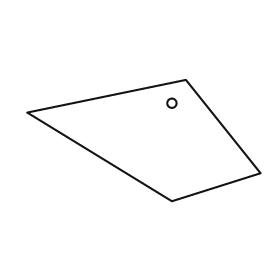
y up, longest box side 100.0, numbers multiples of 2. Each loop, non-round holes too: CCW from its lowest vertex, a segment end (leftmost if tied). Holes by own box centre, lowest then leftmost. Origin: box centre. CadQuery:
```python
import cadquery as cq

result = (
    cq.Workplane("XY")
    .moveTo(12.0, -26.0)
    .lineTo(50.0, -14.0)
    .lineTo(18.0, 26.0)
    .lineTo(-50.0, 12.0)
    .close()
    .moveTo(12.0, 16.0)
    .circle(2.0)
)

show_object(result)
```